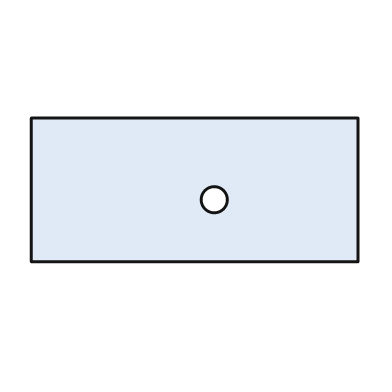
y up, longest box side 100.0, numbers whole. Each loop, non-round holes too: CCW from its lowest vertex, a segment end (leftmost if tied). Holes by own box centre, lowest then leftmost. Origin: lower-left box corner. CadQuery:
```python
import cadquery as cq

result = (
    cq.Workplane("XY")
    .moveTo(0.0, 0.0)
    .lineTo(100.0, 0.0)
    .lineTo(100.0, 44.0)
    .lineTo(0.0, 44.0)
    .close()
    .moveTo(56.0, 19.0)
    .circle(4.0)
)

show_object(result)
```